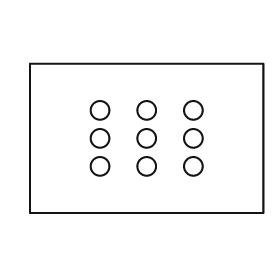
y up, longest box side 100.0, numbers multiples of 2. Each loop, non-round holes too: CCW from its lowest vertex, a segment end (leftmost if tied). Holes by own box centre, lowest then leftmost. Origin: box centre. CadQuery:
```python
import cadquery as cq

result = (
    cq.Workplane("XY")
    .moveTo(-50.0, -32.0)
    .lineTo(50.0, -32.0)
    .lineTo(50.0, 32.0)
    .lineTo(-50.0, 32.0)
    .close()
    .moveTo(-20.0, -12.0)
    .circle(4.0)
    .moveTo(0.0, -12.0)
    .circle(4.0)
    .moveTo(20.0, -12.0)
    .circle(4.0)
    .moveTo(-20.0, 0.0)
    .circle(4.0)
    .moveTo(0.0, 0.0)
    .circle(4.0)
    .moveTo(20.0, 0.0)
    .circle(4.0)
    .moveTo(-20.0, 12.0)
    .circle(4.0)
    .moveTo(0.0, 12.0)
    .circle(4.0)
    .moveTo(20.0, 12.0)
    .circle(4.0)
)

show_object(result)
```